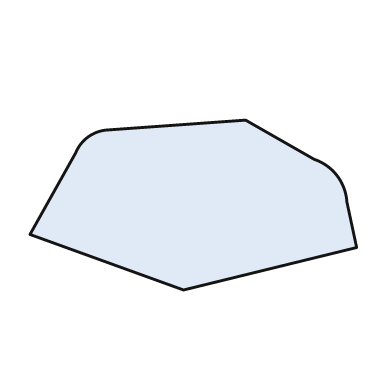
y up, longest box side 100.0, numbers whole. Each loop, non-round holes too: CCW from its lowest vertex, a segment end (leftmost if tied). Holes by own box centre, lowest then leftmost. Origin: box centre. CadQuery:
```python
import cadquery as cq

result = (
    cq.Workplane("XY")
    .moveTo(-3.0, -26.0)
    .lineTo(50.0, -13.0)
    .lineTo(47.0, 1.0)
    .threePointArc((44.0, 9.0), (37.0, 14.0))
    .lineTo(16.0, 26.0)
    .lineTo(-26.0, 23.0)
    .threePointArc((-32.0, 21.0), (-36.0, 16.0))
    .lineTo(-50.0, -9.0)
    .close()
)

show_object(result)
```